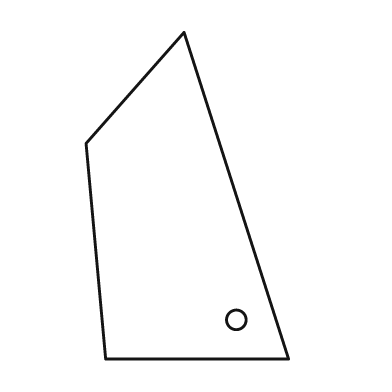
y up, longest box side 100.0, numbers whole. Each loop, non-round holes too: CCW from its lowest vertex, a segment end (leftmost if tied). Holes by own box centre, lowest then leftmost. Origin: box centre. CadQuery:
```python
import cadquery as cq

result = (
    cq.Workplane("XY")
    .moveTo(-25.0, -50.0)
    .lineTo(31.0, -50.0)
    .lineTo(-1.0, 50.0)
    .lineTo(-31.0, 16.0)
    .close()
    .moveTo(15.0, -38.0)
    .circle(3.0)
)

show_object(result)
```